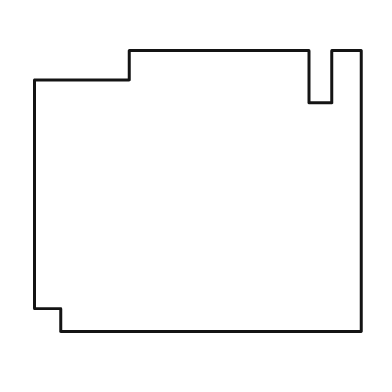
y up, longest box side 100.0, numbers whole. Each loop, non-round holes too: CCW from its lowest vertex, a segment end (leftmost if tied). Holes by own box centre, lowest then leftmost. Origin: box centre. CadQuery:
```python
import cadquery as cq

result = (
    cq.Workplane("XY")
    .moveTo(-42.0, -43.0)
    .lineTo(50.0, -43.0)
    .lineTo(50.0, 43.0)
    .lineTo(41.0, 43.0)
    .lineTo(41.0, 27.0)
    .lineTo(34.0, 27.0)
    .lineTo(34.0, 43.0)
    .lineTo(-21.0, 43.0)
    .lineTo(-21.0, 34.0)
    .lineTo(-50.0, 34.0)
    .lineTo(-50.0, -36.0)
    .lineTo(-42.0, -36.0)
    .close()
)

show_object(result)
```